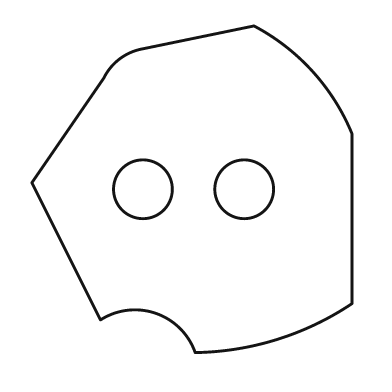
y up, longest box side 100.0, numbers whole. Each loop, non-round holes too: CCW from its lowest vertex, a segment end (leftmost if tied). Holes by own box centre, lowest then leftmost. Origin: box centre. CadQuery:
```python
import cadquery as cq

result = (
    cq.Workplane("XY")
    .moveTo(1.0, -50.0)
    .threePointArc((26.0, -46.0), (49.0, -35.0))
    .lineTo(49.0, 17.0)
    .threePointArc((37.0, 36.0), (19.0, 50.0))
    .lineTo(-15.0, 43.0)
    .threePointArc((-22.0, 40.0), (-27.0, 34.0))
    .lineTo(-49.0, 2.0)
    .lineTo(-28.0, -40.0)
    .threePointArc((-11.0, -38.0), (1.0, -50.0))
    .close()
    .moveTo(-15.0, 0.0)
    .circle(9.0)
    .moveTo(16.0, 0.0)
    .circle(9.0)
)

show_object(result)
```